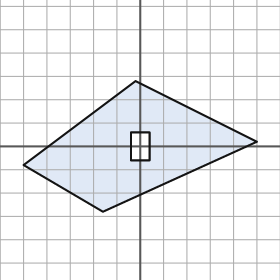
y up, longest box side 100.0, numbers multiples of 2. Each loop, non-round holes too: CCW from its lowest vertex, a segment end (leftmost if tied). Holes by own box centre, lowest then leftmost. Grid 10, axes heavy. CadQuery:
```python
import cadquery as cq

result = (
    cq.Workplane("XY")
    .moveTo(-16.0, -28.0)
    .lineTo(50.0, 2.0)
    .lineTo(-2.0, 28.0)
    .lineTo(-50.0, -8.0)
    .close()
    .moveTo(-4.0, -6.0)
    .lineTo(4.0, -6.0)
    .lineTo(4.0, 6.0)
    .lineTo(-4.0, 6.0)
    .close()
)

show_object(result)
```